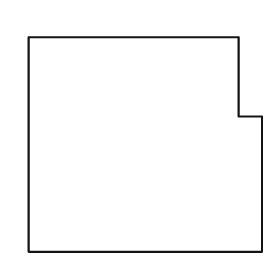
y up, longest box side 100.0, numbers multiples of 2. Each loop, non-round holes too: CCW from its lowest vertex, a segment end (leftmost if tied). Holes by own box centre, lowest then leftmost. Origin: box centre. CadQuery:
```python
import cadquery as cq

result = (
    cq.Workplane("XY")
    .moveTo(-50.0, -46.0)
    .lineTo(50.0, -46.0)
    .lineTo(50.0, 12.0)
    .lineTo(40.0, 12.0)
    .lineTo(40.0, 46.0)
    .lineTo(-50.0, 46.0)
    .close()
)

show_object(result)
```